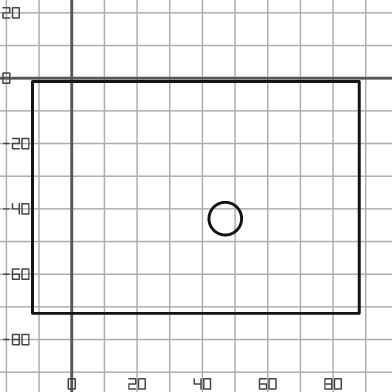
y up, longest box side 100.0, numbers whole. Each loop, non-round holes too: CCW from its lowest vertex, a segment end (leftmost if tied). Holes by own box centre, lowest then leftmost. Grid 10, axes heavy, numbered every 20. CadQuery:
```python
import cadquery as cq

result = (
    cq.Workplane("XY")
    .moveTo(-12.0, -72.0)
    .lineTo(88.0, -72.0)
    .lineTo(88.0, -1.0)
    .lineTo(-12.0, -1.0)
    .close()
    .moveTo(47.0, -43.0)
    .circle(5.0)
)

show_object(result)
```